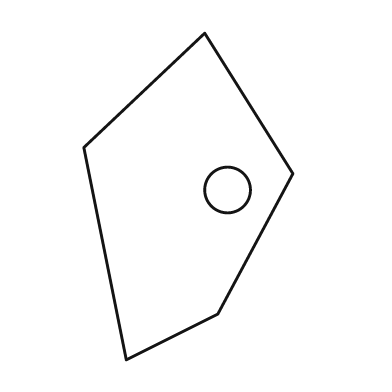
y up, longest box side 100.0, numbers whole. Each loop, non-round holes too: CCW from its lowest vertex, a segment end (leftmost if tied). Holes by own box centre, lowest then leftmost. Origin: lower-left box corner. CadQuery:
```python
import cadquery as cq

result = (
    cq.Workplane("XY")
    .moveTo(13.0, 0.0)
    .lineTo(41.0, 14.0)
    .lineTo(64.0, 57.0)
    .lineTo(37.0, 100.0)
    .lineTo(0.0, 65.0)
    .close()
    .moveTo(44.0, 52.0)
    .circle(7.0)
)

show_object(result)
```